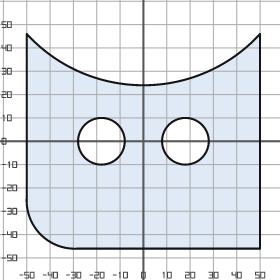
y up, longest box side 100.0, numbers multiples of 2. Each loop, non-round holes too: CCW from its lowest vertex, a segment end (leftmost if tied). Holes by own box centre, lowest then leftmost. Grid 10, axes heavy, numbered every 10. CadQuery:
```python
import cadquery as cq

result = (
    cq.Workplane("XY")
    .moveTo(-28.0, -46.0)
    .lineTo(50.0, -46.0)
    .lineTo(50.0, 46.0)
    .threePointArc((0.0, 24.0), (-50.0, 46.0))
    .lineTo(-50.0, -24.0)
    .threePointArc((-44.0, -40.0), (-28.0, -46.0))
    .close()
    .moveTo(-18.0, 0.0)
    .circle(10.0)
    .moveTo(18.0, 0.0)
    .circle(10.0)
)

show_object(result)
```